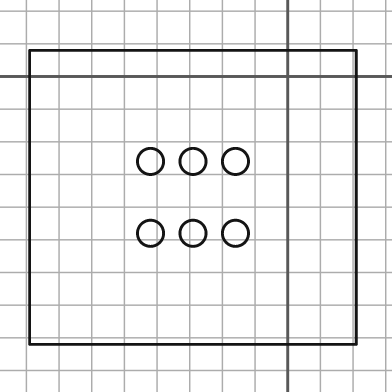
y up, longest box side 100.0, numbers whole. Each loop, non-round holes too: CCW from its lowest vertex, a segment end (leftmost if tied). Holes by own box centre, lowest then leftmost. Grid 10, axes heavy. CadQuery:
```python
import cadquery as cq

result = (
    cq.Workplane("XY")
    .moveTo(-79.0, -82.0)
    .lineTo(21.0, -82.0)
    .lineTo(21.0, 8.0)
    .lineTo(-79.0, 8.0)
    .close()
    .moveTo(-42.0, -48.0)
    .circle(4.0)
    .moveTo(-29.0, -48.0)
    .circle(4.0)
    .moveTo(-16.0, -48.0)
    .circle(4.0)
    .moveTo(-42.0, -26.0)
    .circle(4.0)
    .moveTo(-29.0, -26.0)
    .circle(4.0)
    .moveTo(-16.0, -26.0)
    .circle(4.0)
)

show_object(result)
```